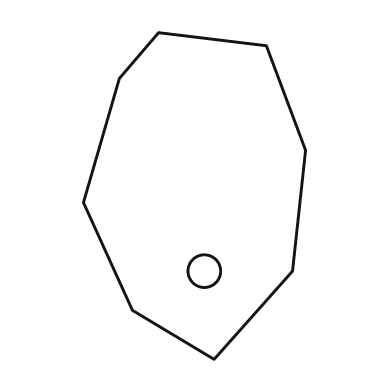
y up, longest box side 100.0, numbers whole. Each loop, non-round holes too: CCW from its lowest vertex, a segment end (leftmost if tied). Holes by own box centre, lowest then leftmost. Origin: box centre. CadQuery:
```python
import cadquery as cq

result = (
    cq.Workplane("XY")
    .moveTo(6.0, -50.0)
    .lineTo(30.0, -23.0)
    .lineTo(34.0, 14.0)
    .lineTo(22.0, 46.0)
    .lineTo(-11.0, 50.0)
    .lineTo(-23.0, 36.0)
    .lineTo(-34.0, -2.0)
    .lineTo(-19.0, -35.0)
    .close()
    .moveTo(3.0, -23.0)
    .circle(5.0)
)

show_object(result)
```